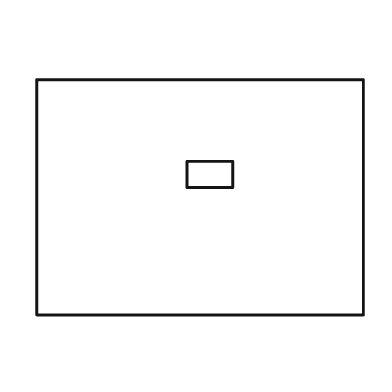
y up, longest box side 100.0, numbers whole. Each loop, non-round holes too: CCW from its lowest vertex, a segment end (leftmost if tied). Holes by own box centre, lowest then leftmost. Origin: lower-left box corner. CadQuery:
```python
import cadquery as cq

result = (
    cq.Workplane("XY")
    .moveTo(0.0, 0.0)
    .lineTo(100.0, 0.0)
    .lineTo(100.0, 72.0)
    .lineTo(0.0, 72.0)
    .close()
    .moveTo(46.0, 39.0)
    .lineTo(60.0, 39.0)
    .lineTo(60.0, 47.0)
    .lineTo(46.0, 47.0)
    .close()
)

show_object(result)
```